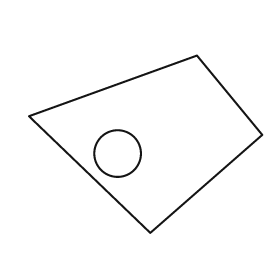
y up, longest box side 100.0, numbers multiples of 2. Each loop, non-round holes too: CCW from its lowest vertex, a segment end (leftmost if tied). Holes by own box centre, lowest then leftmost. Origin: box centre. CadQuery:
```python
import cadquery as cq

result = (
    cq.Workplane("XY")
    .moveTo(2.0, -38.0)
    .lineTo(50.0, 4.0)
    .lineTo(22.0, 38.0)
    .lineTo(-50.0, 12.0)
    .close()
    .moveTo(-12.0, -4.0)
    .circle(10.0)
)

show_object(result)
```